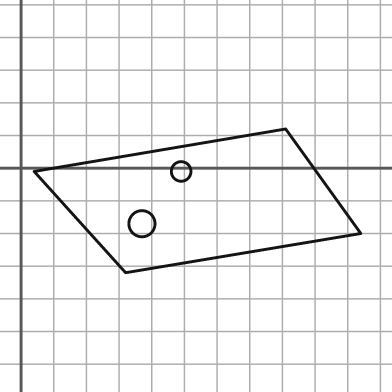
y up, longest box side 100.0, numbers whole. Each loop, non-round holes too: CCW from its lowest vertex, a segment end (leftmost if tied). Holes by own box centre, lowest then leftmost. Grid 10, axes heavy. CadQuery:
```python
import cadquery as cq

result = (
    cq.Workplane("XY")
    .moveTo(32.0, -32.0)
    .lineTo(104.0, -20.0)
    .lineTo(81.0, 12.0)
    .lineTo(4.0, -1.0)
    .close()
    .moveTo(37.0, -17.0)
    .circle(4.0)
    .moveTo(49.0, -1.0)
    .circle(3.0)
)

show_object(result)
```